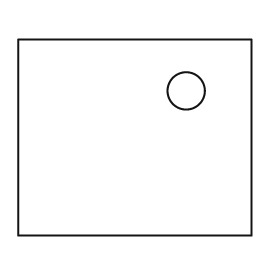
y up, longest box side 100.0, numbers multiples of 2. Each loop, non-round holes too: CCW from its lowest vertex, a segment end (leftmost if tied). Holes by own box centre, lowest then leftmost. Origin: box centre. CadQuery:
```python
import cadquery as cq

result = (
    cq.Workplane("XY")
    .moveTo(-50.0, -42.0)
    .lineTo(50.0, -42.0)
    .lineTo(50.0, 42.0)
    .lineTo(-50.0, 42.0)
    .close()
    .moveTo(22.0, 20.0)
    .circle(8.0)
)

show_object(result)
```